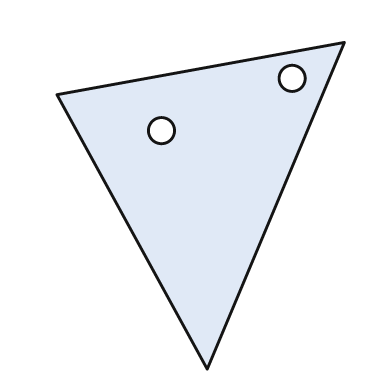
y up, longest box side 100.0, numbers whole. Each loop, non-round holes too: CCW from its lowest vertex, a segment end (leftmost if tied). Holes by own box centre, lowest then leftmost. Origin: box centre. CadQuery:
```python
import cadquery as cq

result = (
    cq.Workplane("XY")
    .moveTo(2.0, -50.0)
    .lineTo(44.0, 50.0)
    .lineTo(-44.0, 34.0)
    .close()
    .moveTo(-12.0, 23.0)
    .circle(4.0)
    .moveTo(28.0, 39.0)
    .circle(4.0)
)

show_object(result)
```